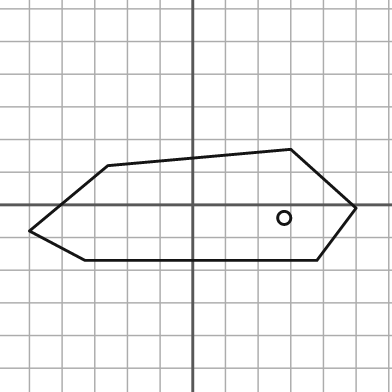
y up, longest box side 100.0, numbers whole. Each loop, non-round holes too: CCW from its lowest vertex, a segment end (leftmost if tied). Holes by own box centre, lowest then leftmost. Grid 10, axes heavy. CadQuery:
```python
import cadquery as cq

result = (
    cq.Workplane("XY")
    .moveTo(-33.0, -17.0)
    .lineTo(38.0, -17.0)
    .lineTo(50.0, -1.0)
    .lineTo(30.0, 17.0)
    .lineTo(-26.0, 12.0)
    .lineTo(-50.0, -8.0)
    .close()
    .moveTo(28.0, -4.0)
    .circle(2.0)
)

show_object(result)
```